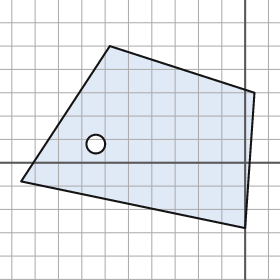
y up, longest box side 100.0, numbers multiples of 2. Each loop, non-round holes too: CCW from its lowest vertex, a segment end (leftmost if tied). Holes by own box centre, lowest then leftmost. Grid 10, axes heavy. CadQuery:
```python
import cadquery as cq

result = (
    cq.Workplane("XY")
    .moveTo(0.0, -28.0)
    .lineTo(4.0, 30.0)
    .lineTo(-58.0, 50.0)
    .lineTo(-96.0, -8.0)
    .close()
    .moveTo(-64.0, 8.0)
    .circle(4.0)
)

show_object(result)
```